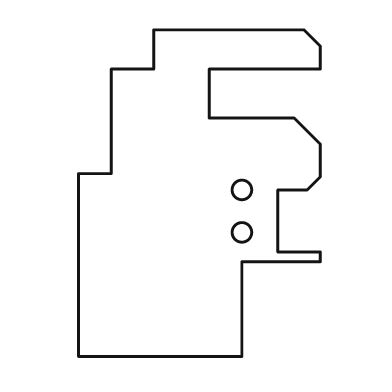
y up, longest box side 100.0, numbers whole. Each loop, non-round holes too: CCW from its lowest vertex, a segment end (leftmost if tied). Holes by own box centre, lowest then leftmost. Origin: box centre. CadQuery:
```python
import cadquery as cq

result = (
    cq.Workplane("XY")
    .moveTo(-37.0, -50.0)
    .lineTo(13.0, -50.0)
    .lineTo(13.0, -21.0)
    .lineTo(37.0, -21.0)
    .lineTo(37.0, -18.0)
    .lineTo(24.0, -18.0)
    .lineTo(24.0, 1.0)
    .lineTo(33.0, 1.0)
    .lineTo(37.0, 5.0)
    .lineTo(37.0, 15.0)
    .lineTo(29.0, 23.0)
    .lineTo(3.0, 23.0)
    .lineTo(3.0, 38.0)
    .lineTo(37.0, 38.0)
    .lineTo(37.0, 45.0)
    .lineTo(32.0, 50.0)
    .lineTo(-14.0, 50.0)
    .lineTo(-14.0, 38.0)
    .lineTo(-27.0, 38.0)
    .lineTo(-27.0, 6.0)
    .lineTo(-37.0, 6.0)
    .close()
    .moveTo(13.0, -12.0)
    .circle(3.0)
    .moveTo(13.0, 1.0)
    .circle(3.0)
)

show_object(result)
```